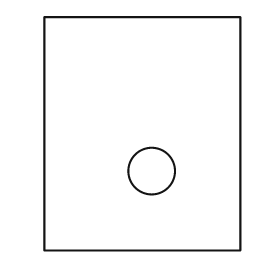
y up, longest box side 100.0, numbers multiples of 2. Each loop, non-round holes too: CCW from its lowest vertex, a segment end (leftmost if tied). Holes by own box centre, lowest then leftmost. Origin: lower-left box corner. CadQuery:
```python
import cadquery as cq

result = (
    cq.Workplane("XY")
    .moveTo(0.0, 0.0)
    .lineTo(84.0, 0.0)
    .lineTo(84.0, 100.0)
    .lineTo(0.0, 100.0)
    .close()
    .moveTo(46.0, 34.0)
    .circle(10.0)
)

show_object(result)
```